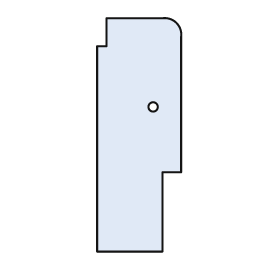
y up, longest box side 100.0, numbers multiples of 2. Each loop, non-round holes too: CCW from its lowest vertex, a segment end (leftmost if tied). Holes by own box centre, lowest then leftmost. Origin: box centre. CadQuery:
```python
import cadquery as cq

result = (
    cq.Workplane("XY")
    .moveTo(-18.0, -50.0)
    .lineTo(10.0, -50.0)
    .lineTo(10.0, -16.0)
    .lineTo(18.0, -16.0)
    .lineTo(18.0, 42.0)
    .threePointArc((16.0, 48.0), (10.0, 50.0))
    .lineTo(-14.0, 50.0)
    .lineTo(-14.0, 38.0)
    .lineTo(-18.0, 38.0)
    .close()
    .moveTo(6.0, 12.0)
    .circle(2.0)
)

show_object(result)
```